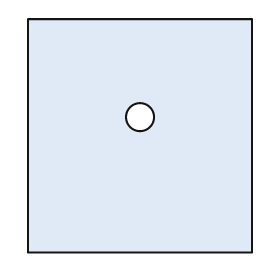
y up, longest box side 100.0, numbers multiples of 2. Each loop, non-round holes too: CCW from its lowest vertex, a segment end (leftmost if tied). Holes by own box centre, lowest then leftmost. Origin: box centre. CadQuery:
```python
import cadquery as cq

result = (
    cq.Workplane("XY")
    .moveTo(-48.0, -50.0)
    .lineTo(48.0, -50.0)
    .lineTo(48.0, 50.0)
    .lineTo(-48.0, 50.0)
    .close()
    .moveTo(0.0, 8.0)
    .circle(6.0)
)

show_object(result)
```